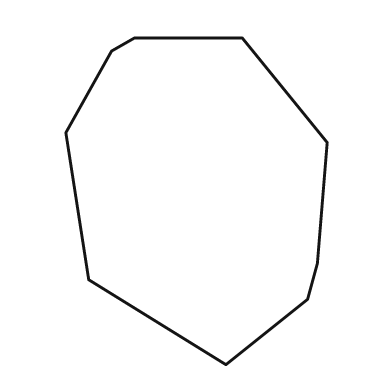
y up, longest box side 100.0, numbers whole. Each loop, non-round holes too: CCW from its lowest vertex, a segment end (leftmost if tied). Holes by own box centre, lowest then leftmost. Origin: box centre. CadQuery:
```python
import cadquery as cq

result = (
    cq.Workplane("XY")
    .moveTo(9.0, -50.0)
    .lineTo(34.0, -30.0)
    .lineTo(37.0, -19.0)
    .lineTo(40.0, 18.0)
    .lineTo(14.0, 50.0)
    .lineTo(-19.0, 50.0)
    .lineTo(-26.0, 46.0)
    .lineTo(-40.0, 21.0)
    .lineTo(-33.0, -24.0)
    .close()
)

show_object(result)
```